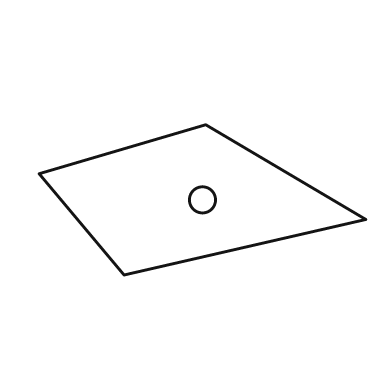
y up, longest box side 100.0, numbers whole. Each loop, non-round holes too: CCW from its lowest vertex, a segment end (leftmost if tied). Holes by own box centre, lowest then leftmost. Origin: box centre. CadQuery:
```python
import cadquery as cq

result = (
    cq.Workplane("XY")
    .moveTo(-24.0, -23.0)
    .lineTo(50.0, -6.0)
    .lineTo(1.0, 23.0)
    .lineTo(-50.0, 8.0)
    .close()
    .moveTo(0.0, 0.0)
    .circle(4.0)
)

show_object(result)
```